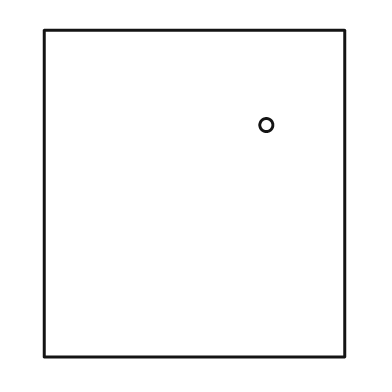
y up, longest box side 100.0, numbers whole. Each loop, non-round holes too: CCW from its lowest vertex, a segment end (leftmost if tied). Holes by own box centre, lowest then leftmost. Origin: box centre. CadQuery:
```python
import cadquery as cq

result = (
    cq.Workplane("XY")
    .moveTo(-46.0, -50.0)
    .lineTo(46.0, -50.0)
    .lineTo(46.0, 50.0)
    .lineTo(-46.0, 50.0)
    .close()
    .moveTo(22.0, 21.0)
    .circle(2.0)
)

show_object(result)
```